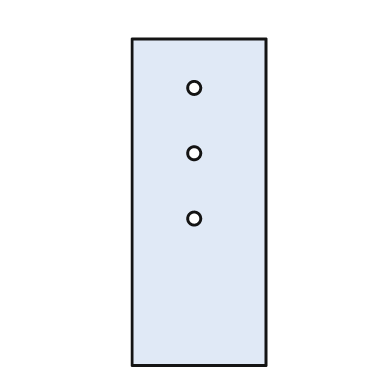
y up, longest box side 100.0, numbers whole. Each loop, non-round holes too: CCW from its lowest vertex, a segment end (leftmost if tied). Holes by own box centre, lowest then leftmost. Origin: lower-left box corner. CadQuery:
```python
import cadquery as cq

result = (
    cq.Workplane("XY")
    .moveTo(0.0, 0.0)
    .lineTo(41.0, 0.0)
    .lineTo(41.0, 100.0)
    .lineTo(0.0, 100.0)
    .close()
    .moveTo(19.0, 45.0)
    .circle(2.0)
    .moveTo(19.0, 65.0)
    .circle(2.0)
    .moveTo(19.0, 85.0)
    .circle(2.0)
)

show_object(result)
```